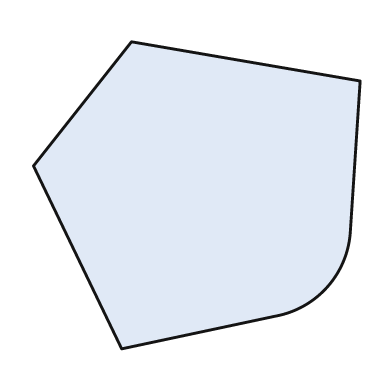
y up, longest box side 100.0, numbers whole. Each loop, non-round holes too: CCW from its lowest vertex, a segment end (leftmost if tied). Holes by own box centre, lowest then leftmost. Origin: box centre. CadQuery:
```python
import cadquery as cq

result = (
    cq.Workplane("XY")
    .moveTo(-23.0, -47.0)
    .lineTo(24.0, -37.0)
    .threePointArc((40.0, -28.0), (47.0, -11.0))
    .lineTo(50.0, 35.0)
    .lineTo(-20.0, 47.0)
    .lineTo(-50.0, 9.0)
    .close()
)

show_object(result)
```